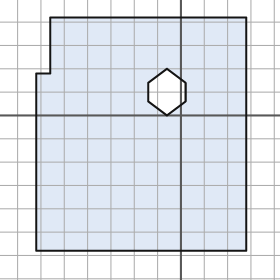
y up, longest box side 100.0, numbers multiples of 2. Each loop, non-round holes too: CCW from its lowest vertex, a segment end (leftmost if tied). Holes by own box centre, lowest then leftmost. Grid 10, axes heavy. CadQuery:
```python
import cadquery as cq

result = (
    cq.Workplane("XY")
    .moveTo(-62.0, -58.0)
    .lineTo(28.0, -58.0)
    .lineTo(28.0, 42.0)
    .lineTo(-56.0, 42.0)
    .lineTo(-56.0, 18.0)
    .lineTo(-62.0, 18.0)
    .close()
    .moveTo(-6.0, 0.0)
    .lineTo(2.0, 6.0)
    .lineTo(2.0, 14.0)
    .lineTo(-6.0, 20.0)
    .lineTo(-14.0, 14.0)
    .lineTo(-14.0, 6.0)
    .close()
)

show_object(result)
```